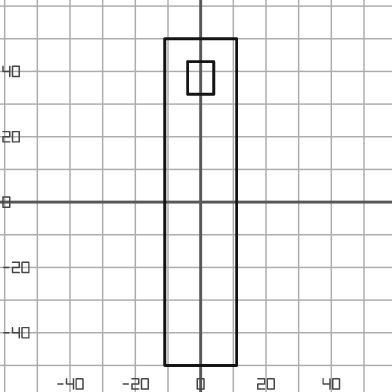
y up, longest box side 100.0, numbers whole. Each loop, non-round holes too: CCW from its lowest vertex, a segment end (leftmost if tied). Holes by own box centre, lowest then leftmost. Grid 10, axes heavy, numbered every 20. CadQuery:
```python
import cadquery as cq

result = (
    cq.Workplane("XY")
    .moveTo(-11.0, -50.0)
    .lineTo(11.0, -50.0)
    .lineTo(11.0, 50.0)
    .lineTo(-11.0, 50.0)
    .close()
    .moveTo(-4.0, 33.0)
    .lineTo(4.0, 33.0)
    .lineTo(4.0, 43.0)
    .lineTo(-4.0, 43.0)
    .close()
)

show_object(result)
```